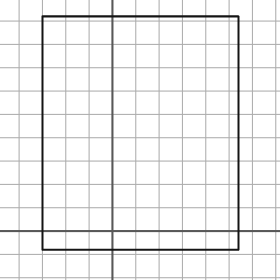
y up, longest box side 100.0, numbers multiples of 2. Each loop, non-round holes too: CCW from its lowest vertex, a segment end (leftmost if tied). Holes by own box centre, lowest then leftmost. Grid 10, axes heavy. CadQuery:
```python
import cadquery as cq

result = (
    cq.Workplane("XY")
    .moveTo(-30.0, -8.0)
    .lineTo(54.0, -8.0)
    .lineTo(54.0, 92.0)
    .lineTo(-30.0, 92.0)
    .close()
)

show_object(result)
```